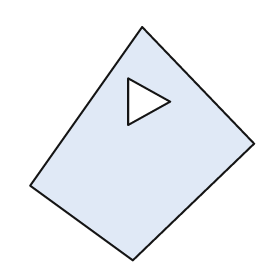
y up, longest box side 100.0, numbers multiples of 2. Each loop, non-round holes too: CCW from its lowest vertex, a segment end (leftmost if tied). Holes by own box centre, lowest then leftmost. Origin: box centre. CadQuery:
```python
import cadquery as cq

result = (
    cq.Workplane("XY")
    .moveTo(-4.0, -50.0)
    .lineTo(48.0, 0.0)
    .lineTo(0.0, 50.0)
    .lineTo(-48.0, -18.0)
    .close()
    .moveTo(-6.0, 8.0)
    .lineTo(12.0, 18.0)
    .lineTo(-6.0, 28.0)
    .close()
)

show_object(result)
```